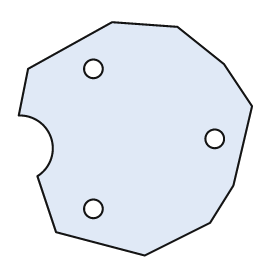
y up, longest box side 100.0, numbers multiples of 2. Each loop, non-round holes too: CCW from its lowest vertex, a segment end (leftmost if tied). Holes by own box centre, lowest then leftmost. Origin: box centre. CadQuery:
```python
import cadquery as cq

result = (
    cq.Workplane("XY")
    .moveTo(4.0, -50.0)
    .lineTo(32.0, -36.0)
    .lineTo(42.0, -20.0)
    .lineTo(50.0, 14.0)
    .lineTo(38.0, 32.0)
    .lineTo(18.0, 48.0)
    .lineTo(-10.0, 50.0)
    .lineTo(-46.0, 30.0)
    .lineTo(-50.0, 10.0)
    .threePointArc((-36.0, 0.0), (-42.0, -16.0))
    .lineTo(-34.0, -40.0)
    .close()
    .moveTo(-18.0, -30.0)
    .circle(4.0)
    .moveTo(34.0, 0.0)
    .circle(4.0)
    .moveTo(-18.0, 30.0)
    .circle(4.0)
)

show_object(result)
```